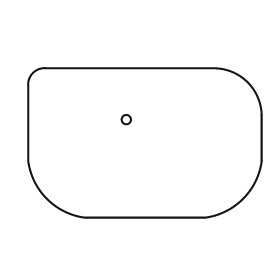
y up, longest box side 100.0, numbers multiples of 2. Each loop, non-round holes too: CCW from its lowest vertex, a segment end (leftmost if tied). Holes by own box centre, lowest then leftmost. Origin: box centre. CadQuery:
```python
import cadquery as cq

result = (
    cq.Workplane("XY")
    .moveTo(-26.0, -32.0)
    .lineTo(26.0, -32.0)
    .threePointArc((42.0, -24.0), (50.0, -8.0))
    .lineTo(50.0, 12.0)
    .threePointArc((44.0, 26.0), (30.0, 32.0))
    .lineTo(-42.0, 32.0)
    .threePointArc((-48.0, 30.0), (-50.0, 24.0))
    .lineTo(-50.0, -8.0)
    .threePointArc((-42.0, -24.0), (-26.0, -32.0))
    .close()
    .moveTo(-8.0, 10.0)
    .circle(2.0)
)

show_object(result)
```